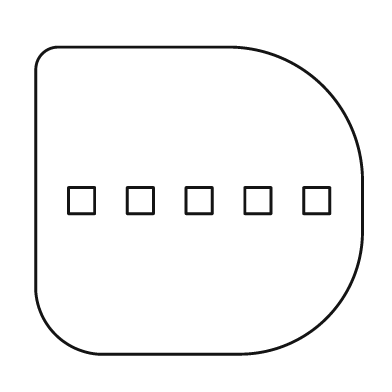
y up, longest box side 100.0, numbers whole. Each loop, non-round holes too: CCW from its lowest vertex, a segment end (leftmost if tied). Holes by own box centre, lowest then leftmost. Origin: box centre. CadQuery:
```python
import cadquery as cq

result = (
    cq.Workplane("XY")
    .moveTo(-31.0, -47.0)
    .lineTo(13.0, -47.0)
    .threePointArc((39.0, -36.0), (50.0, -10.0))
    .lineTo(50.0, 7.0)
    .threePointArc((38.0, 35.0), (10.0, 47.0))
    .lineTo(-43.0, 47.0)
    .threePointArc((-48.0, 45.0), (-50.0, 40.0))
    .lineTo(-50.0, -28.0)
    .threePointArc((-44.0, -41.0), (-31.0, -47.0))
    .close()
    .moveTo(-40.0, -4.0)
    .lineTo(-32.0, -4.0)
    .lineTo(-32.0, 4.0)
    .lineTo(-40.0, 4.0)
    .close()
    .moveTo(-22.0, -4.0)
    .lineTo(-14.0, -4.0)
    .lineTo(-14.0, 4.0)
    .lineTo(-22.0, 4.0)
    .close()
    .moveTo(-4.0, -4.0)
    .lineTo(4.0, -4.0)
    .lineTo(4.0, 4.0)
    .lineTo(-4.0, 4.0)
    .close()
    .moveTo(14.0, -4.0)
    .lineTo(22.0, -4.0)
    .lineTo(22.0, 4.0)
    .lineTo(14.0, 4.0)
    .close()
    .moveTo(32.0, -4.0)
    .lineTo(40.0, -4.0)
    .lineTo(40.0, 4.0)
    .lineTo(32.0, 4.0)
    .close()
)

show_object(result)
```